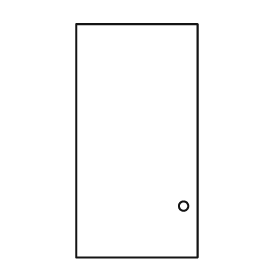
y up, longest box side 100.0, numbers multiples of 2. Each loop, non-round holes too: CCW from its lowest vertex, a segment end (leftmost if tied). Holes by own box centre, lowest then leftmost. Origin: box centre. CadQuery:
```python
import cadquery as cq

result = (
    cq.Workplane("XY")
    .moveTo(-26.0, -50.0)
    .lineTo(26.0, -50.0)
    .lineTo(26.0, 50.0)
    .lineTo(-26.0, 50.0)
    .close()
    .moveTo(20.0, -28.0)
    .circle(2.0)
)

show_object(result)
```